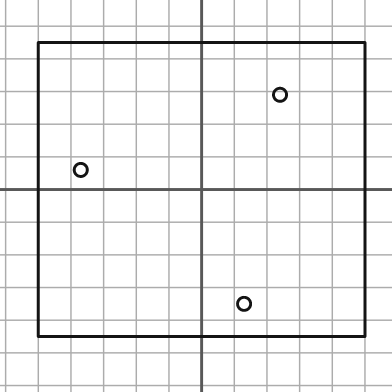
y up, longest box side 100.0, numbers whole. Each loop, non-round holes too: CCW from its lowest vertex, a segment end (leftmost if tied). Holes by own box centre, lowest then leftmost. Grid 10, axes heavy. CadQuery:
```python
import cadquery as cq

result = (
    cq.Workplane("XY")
    .moveTo(-50.0, -45.0)
    .lineTo(50.0, -45.0)
    .lineTo(50.0, 45.0)
    .lineTo(-50.0, 45.0)
    .close()
    .moveTo(13.0, -35.0)
    .circle(2.0)
    .moveTo(-37.0, 6.0)
    .circle(2.0)
    .moveTo(24.0, 29.0)
    .circle(2.0)
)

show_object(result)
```